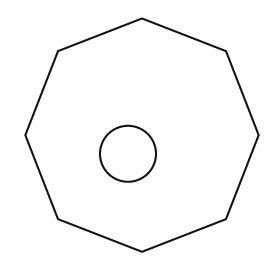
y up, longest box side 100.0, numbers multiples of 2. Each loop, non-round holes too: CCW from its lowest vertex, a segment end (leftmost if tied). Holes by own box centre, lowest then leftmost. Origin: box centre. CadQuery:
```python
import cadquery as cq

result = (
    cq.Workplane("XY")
    .moveTo(0.0, -50.0)
    .lineTo(36.0, -36.0)
    .lineTo(50.0, 0.0)
    .lineTo(36.0, 36.0)
    .lineTo(0.0, 50.0)
    .lineTo(-36.0, 36.0)
    .lineTo(-50.0, 0.0)
    .lineTo(-36.0, -36.0)
    .close()
    .moveTo(-6.0, -8.0)
    .circle(12.0)
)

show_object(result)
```